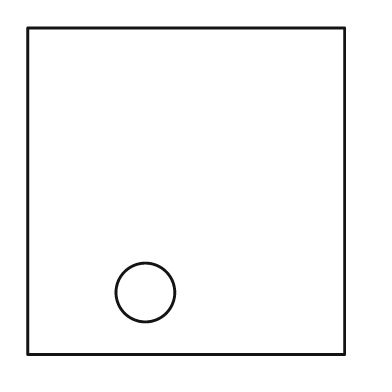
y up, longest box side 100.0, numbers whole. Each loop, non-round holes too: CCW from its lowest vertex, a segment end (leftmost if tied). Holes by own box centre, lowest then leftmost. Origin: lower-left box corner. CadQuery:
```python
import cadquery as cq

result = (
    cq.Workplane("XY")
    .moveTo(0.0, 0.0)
    .lineTo(97.0, 0.0)
    .lineTo(97.0, 100.0)
    .lineTo(0.0, 100.0)
    .close()
    .moveTo(36.0, 19.0)
    .circle(9.0)
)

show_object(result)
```